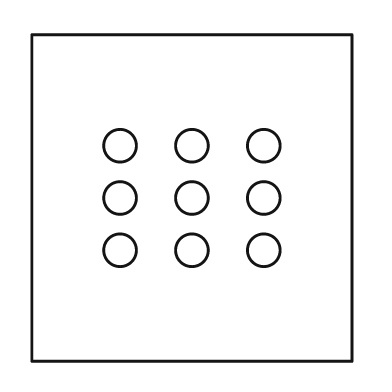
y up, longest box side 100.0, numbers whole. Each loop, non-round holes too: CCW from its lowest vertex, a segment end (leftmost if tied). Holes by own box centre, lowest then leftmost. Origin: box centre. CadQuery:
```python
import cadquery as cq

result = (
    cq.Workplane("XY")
    .moveTo(-49.0, -50.0)
    .lineTo(49.0, -50.0)
    .lineTo(49.0, 50.0)
    .lineTo(-49.0, 50.0)
    .close()
    .moveTo(-22.0, -16.0)
    .circle(5.0)
    .moveTo(0.0, -16.0)
    .circle(5.0)
    .moveTo(22.0, -16.0)
    .circle(5.0)
    .moveTo(-22.0, 0.0)
    .circle(5.0)
    .moveTo(0.0, 0.0)
    .circle(5.0)
    .moveTo(22.0, 0.0)
    .circle(5.0)
    .moveTo(-22.0, 16.0)
    .circle(5.0)
    .moveTo(0.0, 16.0)
    .circle(5.0)
    .moveTo(22.0, 16.0)
    .circle(5.0)
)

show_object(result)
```